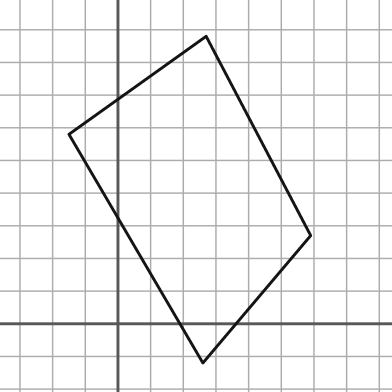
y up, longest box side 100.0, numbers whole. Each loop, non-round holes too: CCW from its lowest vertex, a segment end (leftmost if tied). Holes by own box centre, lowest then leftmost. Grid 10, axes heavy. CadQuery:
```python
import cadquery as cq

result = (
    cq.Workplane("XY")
    .moveTo(26.0, -12.0)
    .lineTo(59.0, 27.0)
    .lineTo(27.0, 88.0)
    .lineTo(-15.0, 58.0)
    .close()
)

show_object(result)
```